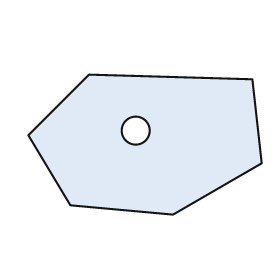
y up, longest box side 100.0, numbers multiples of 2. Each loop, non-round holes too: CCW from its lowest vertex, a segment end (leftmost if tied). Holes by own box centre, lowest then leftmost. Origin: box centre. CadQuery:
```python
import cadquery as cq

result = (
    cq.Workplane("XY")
    .moveTo(12.0, -30.0)
    .lineTo(50.0, -8.0)
    .lineTo(46.0, 28.0)
    .lineTo(-24.0, 30.0)
    .lineTo(-50.0, 4.0)
    .lineTo(-32.0, -26.0)
    .close()
    .moveTo(-4.0, 6.0)
    .circle(6.0)
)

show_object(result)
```